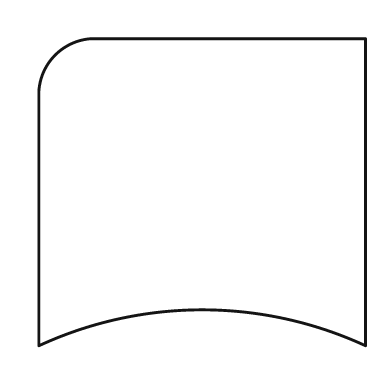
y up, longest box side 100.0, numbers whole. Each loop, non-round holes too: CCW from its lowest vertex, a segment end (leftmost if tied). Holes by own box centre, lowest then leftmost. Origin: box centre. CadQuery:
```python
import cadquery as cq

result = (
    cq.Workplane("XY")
    .moveTo(-50.0, -47.0)
    .threePointArc((0.0, -36.0), (50.0, -47.0))
    .lineTo(50.0, 47.0)
    .lineTo(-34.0, 47.0)
    .threePointArc((-45.0, 42.0), (-50.0, 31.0))
    .close()
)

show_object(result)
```